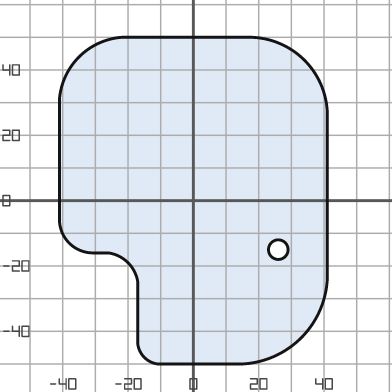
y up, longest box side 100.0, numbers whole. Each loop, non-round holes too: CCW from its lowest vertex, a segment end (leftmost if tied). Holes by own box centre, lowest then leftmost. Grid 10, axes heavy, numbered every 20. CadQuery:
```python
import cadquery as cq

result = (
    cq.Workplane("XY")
    .moveTo(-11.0, -50.0)
    .lineTo(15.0, -50.0)
    .threePointArc((33.0, -42.0), (41.0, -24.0))
    .lineTo(41.0, 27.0)
    .threePointArc((34.0, 43.0), (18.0, 50.0))
    .lineTo(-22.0, 50.0)
    .threePointArc((-35.0, 44.0), (-41.0, 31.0))
    .lineTo(-41.0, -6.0)
    .threePointArc((-38.0, -13.0), (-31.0, -16.0))
    .lineTo(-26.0, -16.0)
    .threePointArc((-20.0, -19.0), (-17.0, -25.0))
    .lineTo(-17.0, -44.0)
    .threePointArc((-15.0, -48.0), (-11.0, -50.0))
    .close()
    .moveTo(26.0, -15.0)
    .circle(3.0)
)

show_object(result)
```